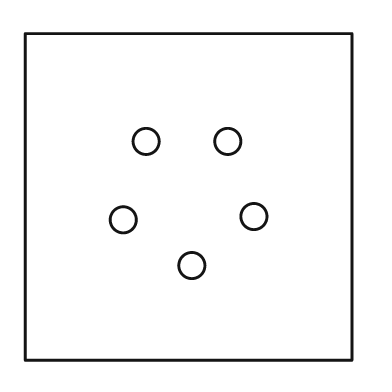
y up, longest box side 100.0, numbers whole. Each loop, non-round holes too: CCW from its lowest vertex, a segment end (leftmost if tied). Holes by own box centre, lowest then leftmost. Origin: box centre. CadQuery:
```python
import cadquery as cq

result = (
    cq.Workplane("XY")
    .moveTo(-50.0, -50.0)
    .lineTo(50.0, -50.0)
    .lineTo(50.0, 50.0)
    .lineTo(-50.0, 50.0)
    .close()
    .moveTo(1.0, -21.0)
    .circle(4.0)
    .moveTo(-20.0, -7.0)
    .circle(4.0)
    .moveTo(20.0, -6.0)
    .circle(4.0)
    .moveTo(-13.0, 17.0)
    .circle(4.0)
    .moveTo(12.0, 17.0)
    .circle(4.0)
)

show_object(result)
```